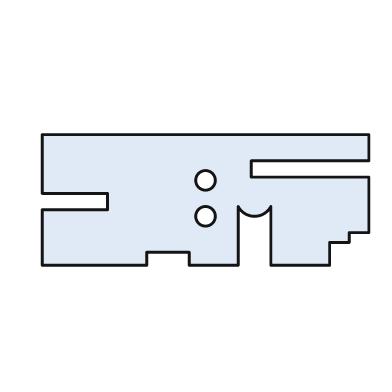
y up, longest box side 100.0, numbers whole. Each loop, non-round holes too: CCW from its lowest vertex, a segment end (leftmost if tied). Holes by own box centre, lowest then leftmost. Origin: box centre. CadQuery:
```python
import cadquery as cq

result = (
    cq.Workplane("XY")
    .moveTo(-50.0, -20.0)
    .lineTo(-18.0, -20.0)
    .lineTo(-18.0, -16.0)
    .lineTo(-5.0, -16.0)
    .lineTo(-5.0, -20.0)
    .lineTo(10.0, -20.0)
    .lineTo(10.0, -2.0)
    .threePointArc((15.0, -5.0), (20.0, -2.0))
    .lineTo(20.0, -20.0)
    .lineTo(38.0, -20.0)
    .lineTo(38.0, -13.0)
    .lineTo(44.0, -13.0)
    .lineTo(44.0, -10.0)
    .lineTo(50.0, -10.0)
    .lineTo(50.0, 7.0)
    .lineTo(14.0, 7.0)
    .lineTo(14.0, 12.0)
    .lineTo(50.0, 12.0)
    .lineTo(50.0, 20.0)
    .lineTo(-50.0, 20.0)
    .lineTo(-50.0, 2.0)
    .lineTo(-30.0, 2.0)
    .lineTo(-30.0, -3.0)
    .lineTo(-50.0, -3.0)
    .close()
    .moveTo(0.0, -5.0)
    .circle(3.0)
    .moveTo(0.0, 6.0)
    .circle(3.0)
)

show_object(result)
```